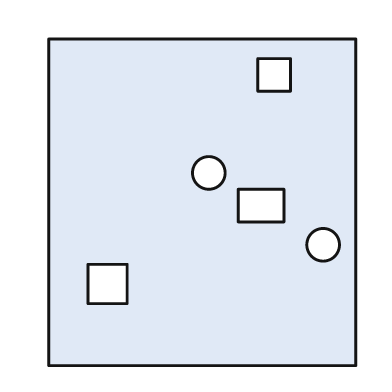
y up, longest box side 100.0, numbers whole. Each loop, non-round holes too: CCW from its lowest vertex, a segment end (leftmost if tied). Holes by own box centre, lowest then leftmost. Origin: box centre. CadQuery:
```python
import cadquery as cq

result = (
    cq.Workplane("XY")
    .moveTo(-47.0, -50.0)
    .lineTo(47.0, -50.0)
    .lineTo(47.0, 50.0)
    .lineTo(-47.0, 50.0)
    .close()
    .moveTo(-35.0, -31.0)
    .lineTo(-23.0, -31.0)
    .lineTo(-23.0, -19.0)
    .lineTo(-35.0, -19.0)
    .close()
    .moveTo(37.0, -13.0)
    .circle(5.0)
    .moveTo(11.0, -6.0)
    .lineTo(25.0, -6.0)
    .lineTo(25.0, 4.0)
    .lineTo(11.0, 4.0)
    .close()
    .moveTo(2.0, 9.0)
    .circle(5.0)
    .moveTo(17.0, 34.0)
    .lineTo(27.0, 34.0)
    .lineTo(27.0, 44.0)
    .lineTo(17.0, 44.0)
    .close()
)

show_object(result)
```